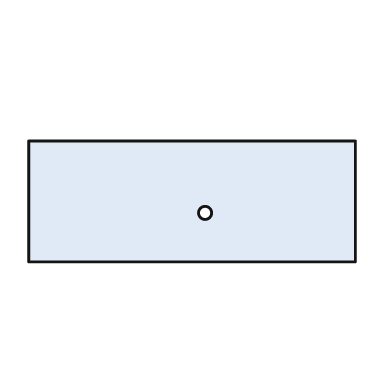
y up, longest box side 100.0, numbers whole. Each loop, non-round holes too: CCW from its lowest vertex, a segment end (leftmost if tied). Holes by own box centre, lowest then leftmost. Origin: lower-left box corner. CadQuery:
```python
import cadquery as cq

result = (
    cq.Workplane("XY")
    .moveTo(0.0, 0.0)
    .lineTo(100.0, 0.0)
    .lineTo(100.0, 37.0)
    .lineTo(0.0, 37.0)
    .close()
    .moveTo(54.0, 15.0)
    .circle(2.0)
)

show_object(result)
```